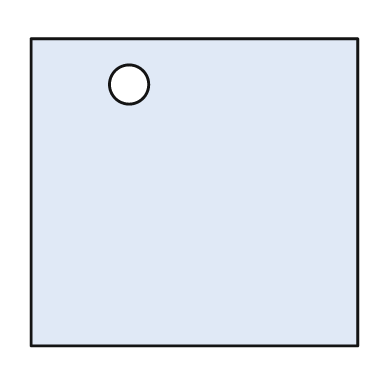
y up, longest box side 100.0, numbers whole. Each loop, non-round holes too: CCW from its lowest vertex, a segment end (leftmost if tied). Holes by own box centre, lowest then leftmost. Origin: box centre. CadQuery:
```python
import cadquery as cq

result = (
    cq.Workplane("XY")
    .moveTo(-50.0, -47.0)
    .lineTo(50.0, -47.0)
    .lineTo(50.0, 47.0)
    .lineTo(-50.0, 47.0)
    .close()
    .moveTo(-20.0, 33.0)
    .circle(6.0)
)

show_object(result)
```